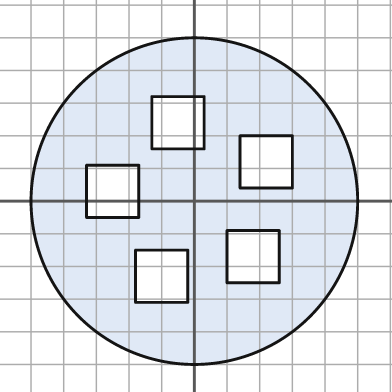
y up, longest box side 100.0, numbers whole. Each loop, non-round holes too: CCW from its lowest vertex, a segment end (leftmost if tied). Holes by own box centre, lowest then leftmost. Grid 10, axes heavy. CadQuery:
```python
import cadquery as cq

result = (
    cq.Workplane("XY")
    .moveTo(0.0, 0.0)
    .circle(50.0)
    .moveTo(-18.0, -31.0)
    .lineTo(-2.0, -31.0)
    .lineTo(-2.0, -15.0)
    .lineTo(-18.0, -15.0)
    .close()
    .moveTo(10.0, -25.0)
    .lineTo(26.0, -25.0)
    .lineTo(26.0, -9.0)
    .lineTo(10.0, -9.0)
    .close()
    .moveTo(-33.0, -5.0)
    .lineTo(-17.0, -5.0)
    .lineTo(-17.0, 11.0)
    .lineTo(-33.0, 11.0)
    .close()
    .moveTo(14.0, 4.0)
    .lineTo(30.0, 4.0)
    .lineTo(30.0, 20.0)
    .lineTo(14.0, 20.0)
    .close()
    .moveTo(-13.0, 16.0)
    .lineTo(3.0, 16.0)
    .lineTo(3.0, 32.0)
    .lineTo(-13.0, 32.0)
    .close()
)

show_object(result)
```